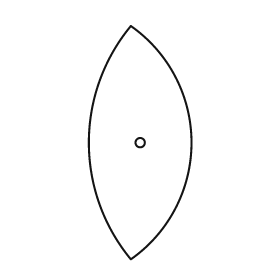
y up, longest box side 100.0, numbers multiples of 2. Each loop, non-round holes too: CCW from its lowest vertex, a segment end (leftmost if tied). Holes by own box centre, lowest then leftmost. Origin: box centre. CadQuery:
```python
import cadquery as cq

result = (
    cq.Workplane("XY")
    .moveTo(-4.0, -50.0)
    .threePointArc((22.0, 0.0), (-4.0, 50.0))
    .threePointArc((-22.0, 0.0), (-4.0, -50.0))
    .close()
    .moveTo(0.0, 0.0)
    .circle(2.0)
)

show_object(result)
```